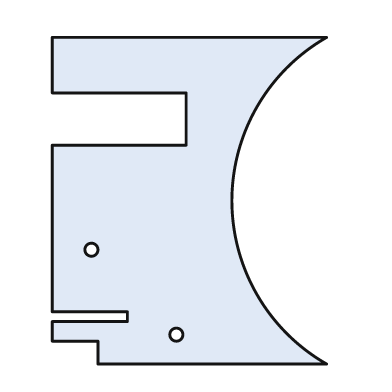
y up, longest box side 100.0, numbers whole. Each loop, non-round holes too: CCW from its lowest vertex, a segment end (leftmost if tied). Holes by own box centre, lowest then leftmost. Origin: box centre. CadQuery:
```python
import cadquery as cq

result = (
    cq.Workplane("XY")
    .moveTo(-28.0, -50.0)
    .lineTo(42.0, -50.0)
    .threePointArc((13.0, 0.0), (42.0, 50.0))
    .lineTo(-42.0, 50.0)
    .lineTo(-42.0, 33.0)
    .lineTo(-1.0, 33.0)
    .lineTo(-1.0, 17.0)
    .lineTo(-42.0, 17.0)
    .lineTo(-42.0, -34.0)
    .lineTo(-19.0, -34.0)
    .lineTo(-19.0, -37.0)
    .lineTo(-42.0, -37.0)
    .lineTo(-42.0, -43.0)
    .lineTo(-28.0, -43.0)
    .close()
    .moveTo(-4.0, -41.0)
    .circle(2.0)
    .moveTo(-30.0, -15.0)
    .circle(2.0)
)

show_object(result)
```